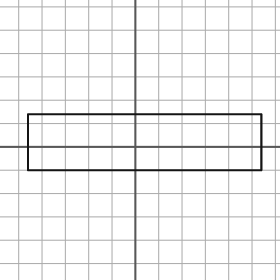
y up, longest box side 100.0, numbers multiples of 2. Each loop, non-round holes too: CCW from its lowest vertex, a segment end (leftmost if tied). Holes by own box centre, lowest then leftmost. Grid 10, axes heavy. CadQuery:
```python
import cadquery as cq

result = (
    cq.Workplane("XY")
    .moveTo(-46.0, -10.0)
    .lineTo(54.0, -10.0)
    .lineTo(54.0, 14.0)
    .lineTo(-46.0, 14.0)
    .close()
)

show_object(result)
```